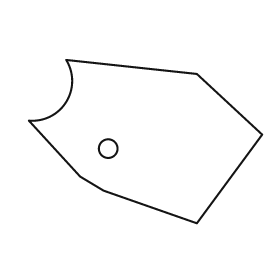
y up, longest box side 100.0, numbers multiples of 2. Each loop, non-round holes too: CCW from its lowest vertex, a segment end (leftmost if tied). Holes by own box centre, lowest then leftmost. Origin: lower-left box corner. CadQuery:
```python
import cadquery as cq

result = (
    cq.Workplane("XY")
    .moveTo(72.0, 0.0)
    .lineTo(100.0, 38.0)
    .lineTo(72.0, 64.0)
    .lineTo(16.0, 70.0)
    .threePointArc((16.0, 52.0), (0.0, 44.0))
    .lineTo(22.0, 20.0)
    .lineTo(32.0, 14.0)
    .close()
    .moveTo(34.0, 32.0)
    .circle(4.0)
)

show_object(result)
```